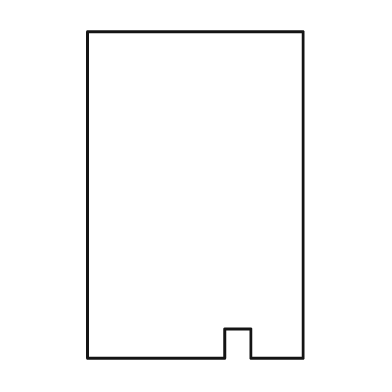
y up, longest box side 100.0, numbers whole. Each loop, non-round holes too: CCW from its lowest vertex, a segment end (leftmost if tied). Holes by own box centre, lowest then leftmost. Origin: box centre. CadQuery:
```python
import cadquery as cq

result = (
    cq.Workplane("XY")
    .moveTo(-33.0, -50.0)
    .lineTo(9.0, -50.0)
    .lineTo(9.0, -41.0)
    .lineTo(17.0, -41.0)
    .lineTo(17.0, -50.0)
    .lineTo(33.0, -50.0)
    .lineTo(33.0, 50.0)
    .lineTo(-33.0, 50.0)
    .close()
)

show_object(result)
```